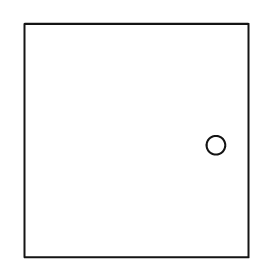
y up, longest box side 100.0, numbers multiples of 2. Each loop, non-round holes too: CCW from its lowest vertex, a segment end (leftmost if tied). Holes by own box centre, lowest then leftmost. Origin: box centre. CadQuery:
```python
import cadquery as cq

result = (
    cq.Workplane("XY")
    .moveTo(-48.0, -50.0)
    .lineTo(48.0, -50.0)
    .lineTo(48.0, 50.0)
    .lineTo(-48.0, 50.0)
    .close()
    .moveTo(34.0, -2.0)
    .circle(4.0)
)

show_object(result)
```